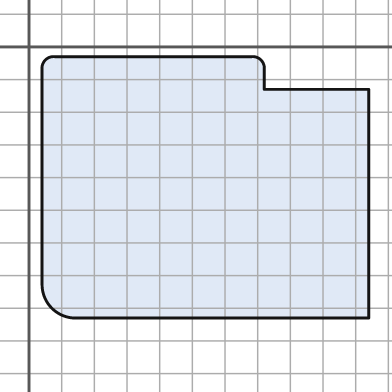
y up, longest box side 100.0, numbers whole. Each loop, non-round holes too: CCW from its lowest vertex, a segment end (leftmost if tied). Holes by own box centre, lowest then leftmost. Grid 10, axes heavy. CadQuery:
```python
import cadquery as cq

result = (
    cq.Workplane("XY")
    .moveTo(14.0, -83.0)
    .lineTo(104.0, -83.0)
    .lineTo(104.0, -13.0)
    .lineTo(72.0, -13.0)
    .lineTo(72.0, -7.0)
    .threePointArc((71.0, -4.0), (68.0, -3.0))
    .lineTo(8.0, -3.0)
    .threePointArc((5.0, -4.0), (4.0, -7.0))
    .lineTo(4.0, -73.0)
    .threePointArc((7.0, -80.0), (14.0, -83.0))
    .close()
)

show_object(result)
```